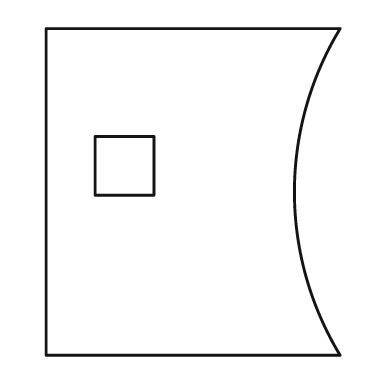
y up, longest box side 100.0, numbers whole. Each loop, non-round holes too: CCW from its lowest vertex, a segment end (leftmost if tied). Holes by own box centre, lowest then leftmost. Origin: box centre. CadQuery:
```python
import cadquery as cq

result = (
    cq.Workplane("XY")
    .moveTo(-45.0, -50.0)
    .lineTo(45.0, -50.0)
    .threePointArc((31.0, 0.0), (45.0, 50.0))
    .lineTo(-45.0, 50.0)
    .close()
    .moveTo(-30.0, -1.0)
    .lineTo(-12.0, -1.0)
    .lineTo(-12.0, 17.0)
    .lineTo(-30.0, 17.0)
    .close()
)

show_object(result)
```